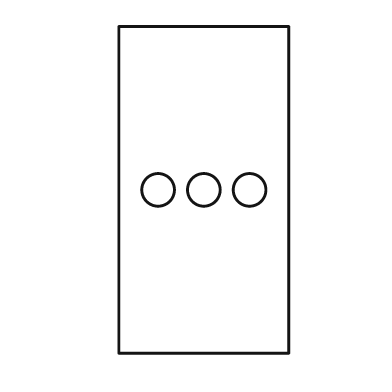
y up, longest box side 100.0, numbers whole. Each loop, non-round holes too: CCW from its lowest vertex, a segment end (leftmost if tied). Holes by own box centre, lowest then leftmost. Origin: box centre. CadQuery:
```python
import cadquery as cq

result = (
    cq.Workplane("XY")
    .moveTo(-26.0, -50.0)
    .lineTo(26.0, -50.0)
    .lineTo(26.0, 50.0)
    .lineTo(-26.0, 50.0)
    .close()
    .moveTo(-14.0, 0.0)
    .circle(5.0)
    .moveTo(0.0, 0.0)
    .circle(5.0)
    .moveTo(14.0, 0.0)
    .circle(5.0)
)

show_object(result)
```